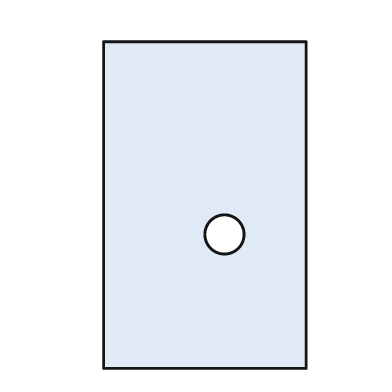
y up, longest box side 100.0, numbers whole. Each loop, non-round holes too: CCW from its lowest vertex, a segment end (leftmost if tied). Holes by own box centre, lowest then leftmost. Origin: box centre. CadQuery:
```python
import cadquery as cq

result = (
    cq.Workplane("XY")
    .moveTo(-31.0, -50.0)
    .lineTo(31.0, -50.0)
    .lineTo(31.0, 50.0)
    .lineTo(-31.0, 50.0)
    .close()
    .moveTo(6.0, -9.0)
    .circle(6.0)
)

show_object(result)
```